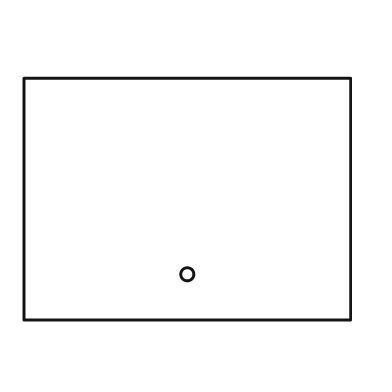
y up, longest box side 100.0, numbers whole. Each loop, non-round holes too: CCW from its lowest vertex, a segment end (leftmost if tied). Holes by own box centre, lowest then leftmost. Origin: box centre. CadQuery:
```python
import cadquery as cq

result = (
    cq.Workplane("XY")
    .moveTo(-50.0, -37.0)
    .lineTo(50.0, -37.0)
    .lineTo(50.0, 37.0)
    .lineTo(-50.0, 37.0)
    .close()
    .moveTo(0.0, -23.0)
    .circle(2.0)
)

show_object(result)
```